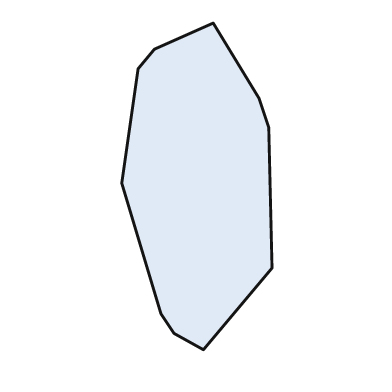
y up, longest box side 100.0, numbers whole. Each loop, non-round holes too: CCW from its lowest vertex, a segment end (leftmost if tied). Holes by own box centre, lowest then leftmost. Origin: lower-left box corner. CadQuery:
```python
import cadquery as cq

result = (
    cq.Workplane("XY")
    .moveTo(25.0, 0.0)
    .lineTo(46.0, 25.0)
    .lineTo(45.0, 68.0)
    .lineTo(42.0, 77.0)
    .lineTo(28.0, 100.0)
    .lineTo(10.0, 92.0)
    .lineTo(5.0, 86.0)
    .lineTo(0.0, 51.0)
    .lineTo(12.0, 11.0)
    .lineTo(16.0, 5.0)
    .close()
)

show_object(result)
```